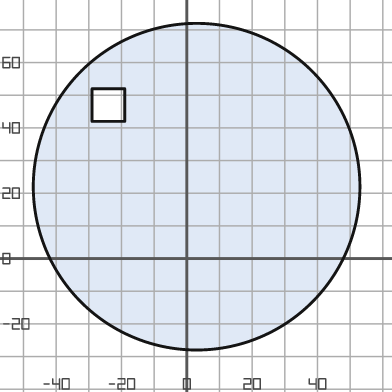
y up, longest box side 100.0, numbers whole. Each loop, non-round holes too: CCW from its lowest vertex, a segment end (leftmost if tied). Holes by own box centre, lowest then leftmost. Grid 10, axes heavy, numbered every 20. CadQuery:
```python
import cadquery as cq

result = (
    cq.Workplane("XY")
    .moveTo(3.0, 22.0)
    .circle(50.0)
    .moveTo(-29.0, 42.0)
    .lineTo(-19.0, 42.0)
    .lineTo(-19.0, 52.0)
    .lineTo(-29.0, 52.0)
    .close()
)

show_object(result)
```